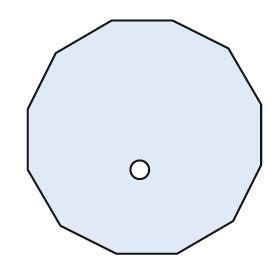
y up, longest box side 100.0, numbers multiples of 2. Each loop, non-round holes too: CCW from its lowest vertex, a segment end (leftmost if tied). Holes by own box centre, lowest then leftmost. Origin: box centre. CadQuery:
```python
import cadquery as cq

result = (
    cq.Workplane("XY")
    .moveTo(-12.0, -50.0)
    .lineTo(14.0, -50.0)
    .lineTo(38.0, -36.0)
    .lineTo(50.0, -12.0)
    .lineTo(50.0, 14.0)
    .lineTo(36.0, 38.0)
    .lineTo(12.0, 50.0)
    .lineTo(-14.0, 50.0)
    .lineTo(-38.0, 36.0)
    .lineTo(-50.0, 12.0)
    .lineTo(-50.0, -14.0)
    .lineTo(-36.0, -38.0)
    .close()
    .moveTo(-2.0, -14.0)
    .circle(4.0)
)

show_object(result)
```